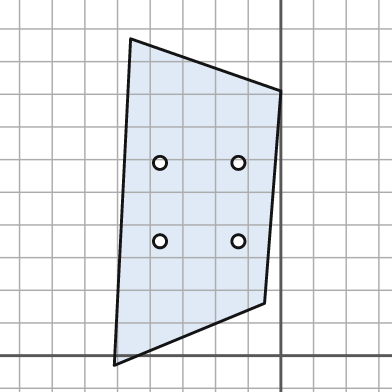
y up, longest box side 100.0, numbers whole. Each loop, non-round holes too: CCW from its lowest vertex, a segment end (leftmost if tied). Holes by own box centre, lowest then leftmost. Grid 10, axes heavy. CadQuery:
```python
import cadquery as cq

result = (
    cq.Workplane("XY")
    .moveTo(-51.0, -3.0)
    .lineTo(-5.0, 16.0)
    .lineTo(0.0, 81.0)
    .lineTo(-46.0, 97.0)
    .close()
    .moveTo(-37.0, 35.0)
    .circle(2.0)
    .moveTo(-13.0, 35.0)
    .circle(2.0)
    .moveTo(-37.0, 59.0)
    .circle(2.0)
    .moveTo(-13.0, 59.0)
    .circle(2.0)
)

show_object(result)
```